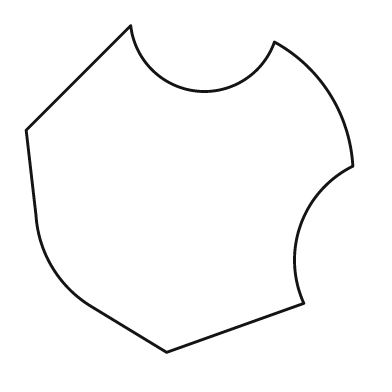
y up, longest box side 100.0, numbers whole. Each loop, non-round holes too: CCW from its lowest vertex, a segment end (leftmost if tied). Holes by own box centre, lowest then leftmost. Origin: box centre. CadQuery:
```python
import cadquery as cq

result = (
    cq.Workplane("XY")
    .moveTo(-7.0, -50.0)
    .lineTo(35.0, -35.0)
    .threePointArc((34.0, -11.0), (50.0, 7.0))
    .threePointArc((43.0, 29.0), (26.0, 45.0))
    .threePointArc((2.0, 30.0), (-18.0, 50.0))
    .lineTo(-50.0, 18.0)
    .lineTo(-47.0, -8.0)
    .threePointArc((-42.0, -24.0), (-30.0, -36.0))
    .close()
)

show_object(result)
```